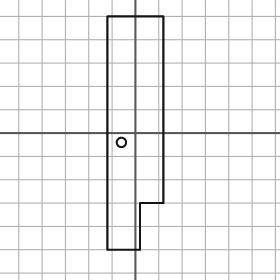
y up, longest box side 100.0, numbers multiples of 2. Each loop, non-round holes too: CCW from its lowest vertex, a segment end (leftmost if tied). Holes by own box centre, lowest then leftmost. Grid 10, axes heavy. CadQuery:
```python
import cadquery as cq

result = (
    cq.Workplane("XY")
    .moveTo(-12.0, -50.0)
    .lineTo(2.0, -50.0)
    .lineTo(2.0, -30.0)
    .lineTo(12.0, -30.0)
    .lineTo(12.0, 50.0)
    .lineTo(-12.0, 50.0)
    .close()
    .moveTo(-6.0, -4.0)
    .circle(2.0)
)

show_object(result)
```